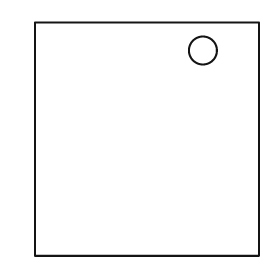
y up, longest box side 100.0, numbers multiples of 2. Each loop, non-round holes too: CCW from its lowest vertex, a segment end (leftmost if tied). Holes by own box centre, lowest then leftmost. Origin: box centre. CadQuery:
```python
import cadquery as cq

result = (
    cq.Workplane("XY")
    .moveTo(-48.0, -50.0)
    .lineTo(48.0, -50.0)
    .lineTo(48.0, 50.0)
    .lineTo(-48.0, 50.0)
    .close()
    .moveTo(24.0, 38.0)
    .circle(6.0)
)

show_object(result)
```